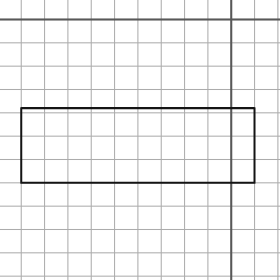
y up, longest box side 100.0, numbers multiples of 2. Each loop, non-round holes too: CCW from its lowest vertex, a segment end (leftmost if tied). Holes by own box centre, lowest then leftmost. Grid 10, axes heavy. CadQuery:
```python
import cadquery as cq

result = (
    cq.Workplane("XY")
    .moveTo(-90.0, -70.0)
    .lineTo(10.0, -70.0)
    .lineTo(10.0, -38.0)
    .lineTo(-90.0, -38.0)
    .close()
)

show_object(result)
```